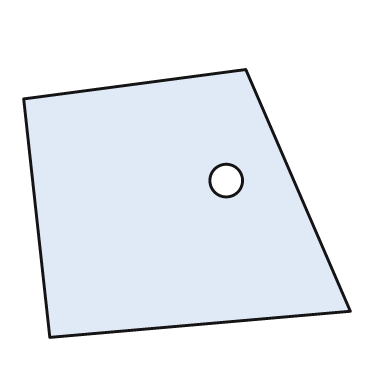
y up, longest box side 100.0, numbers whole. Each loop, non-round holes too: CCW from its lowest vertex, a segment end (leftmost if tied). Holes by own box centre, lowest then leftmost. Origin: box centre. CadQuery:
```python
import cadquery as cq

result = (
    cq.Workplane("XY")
    .moveTo(-42.0, -41.0)
    .lineTo(50.0, -33.0)
    .lineTo(18.0, 41.0)
    .lineTo(-50.0, 32.0)
    .close()
    .moveTo(12.0, 7.0)
    .circle(5.0)
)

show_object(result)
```